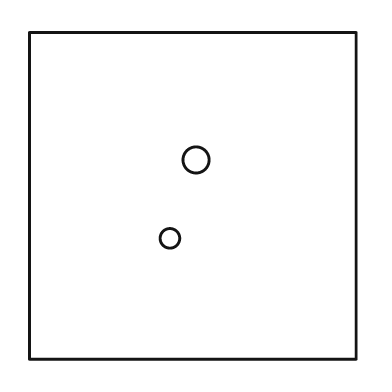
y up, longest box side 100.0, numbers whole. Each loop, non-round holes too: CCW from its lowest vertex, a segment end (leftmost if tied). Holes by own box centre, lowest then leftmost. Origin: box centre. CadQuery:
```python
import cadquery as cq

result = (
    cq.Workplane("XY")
    .moveTo(-50.0, -50.0)
    .lineTo(50.0, -50.0)
    .lineTo(50.0, 50.0)
    .lineTo(-50.0, 50.0)
    .close()
    .moveTo(-7.0, -13.0)
    .circle(3.0)
    .moveTo(1.0, 11.0)
    .circle(4.0)
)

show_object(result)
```